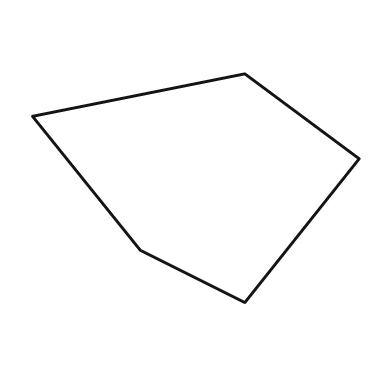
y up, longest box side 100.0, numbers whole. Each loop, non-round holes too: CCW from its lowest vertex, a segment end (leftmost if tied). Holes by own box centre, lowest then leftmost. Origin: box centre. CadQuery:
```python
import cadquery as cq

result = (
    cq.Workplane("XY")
    .moveTo(15.0, -35.0)
    .lineTo(50.0, 9.0)
    .lineTo(15.0, 35.0)
    .lineTo(-50.0, 22.0)
    .lineTo(-17.0, -19.0)
    .close()
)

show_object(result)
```